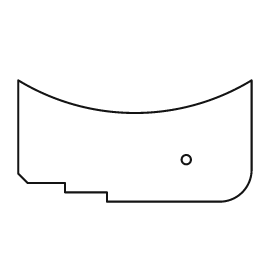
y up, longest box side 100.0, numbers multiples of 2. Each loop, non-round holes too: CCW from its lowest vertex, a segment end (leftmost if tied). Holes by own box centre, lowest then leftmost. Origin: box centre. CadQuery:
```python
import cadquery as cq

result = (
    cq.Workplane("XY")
    .moveTo(-12.0, -26.0)
    .lineTo(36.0, -26.0)
    .threePointArc((46.0, -22.0), (50.0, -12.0))
    .lineTo(50.0, 26.0)
    .threePointArc((0.0, 12.0), (-50.0, 26.0))
    .lineTo(-50.0, -14.0)
    .lineTo(-46.0, -18.0)
    .lineTo(-30.0, -18.0)
    .lineTo(-30.0, -22.0)
    .lineTo(-12.0, -22.0)
    .close()
    .moveTo(22.0, -8.0)
    .circle(2.0)
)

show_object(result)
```